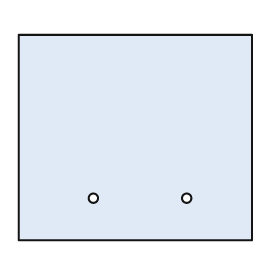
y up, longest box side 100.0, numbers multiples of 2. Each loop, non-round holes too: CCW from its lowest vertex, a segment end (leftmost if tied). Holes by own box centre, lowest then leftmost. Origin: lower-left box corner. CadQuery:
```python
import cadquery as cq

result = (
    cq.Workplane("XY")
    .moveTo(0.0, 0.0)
    .lineTo(100.0, 0.0)
    .lineTo(100.0, 88.0)
    .lineTo(0.0, 88.0)
    .close()
    .moveTo(32.0, 18.0)
    .circle(2.0)
    .moveTo(72.0, 18.0)
    .circle(2.0)
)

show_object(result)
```